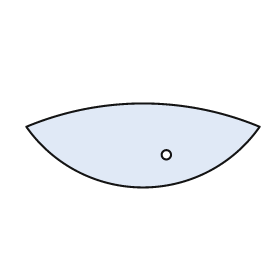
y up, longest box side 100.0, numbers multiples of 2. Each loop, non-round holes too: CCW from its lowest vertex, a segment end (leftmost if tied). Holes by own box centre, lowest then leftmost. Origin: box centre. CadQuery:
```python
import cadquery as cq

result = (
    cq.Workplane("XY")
    .moveTo(-50.0, 8.0)
    .threePointArc((0.0, -18.0), (50.0, 8.0))
    .threePointArc((0.0, 18.0), (-50.0, 8.0))
    .close()
    .moveTo(10.0, -4.0)
    .circle(2.0)
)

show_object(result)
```